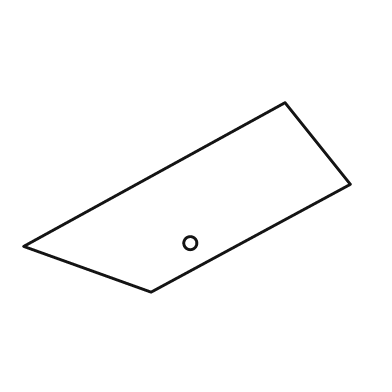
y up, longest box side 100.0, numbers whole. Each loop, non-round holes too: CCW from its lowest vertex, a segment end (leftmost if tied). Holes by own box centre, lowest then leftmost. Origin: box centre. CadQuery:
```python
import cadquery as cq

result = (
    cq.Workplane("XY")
    .moveTo(-11.0, -29.0)
    .lineTo(50.0, 4.0)
    .lineTo(30.0, 29.0)
    .lineTo(-50.0, -15.0)
    .close()
    .moveTo(1.0, -14.0)
    .circle(2.0)
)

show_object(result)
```